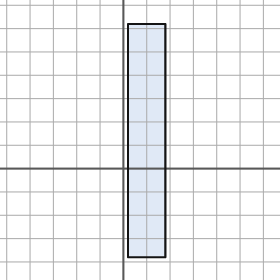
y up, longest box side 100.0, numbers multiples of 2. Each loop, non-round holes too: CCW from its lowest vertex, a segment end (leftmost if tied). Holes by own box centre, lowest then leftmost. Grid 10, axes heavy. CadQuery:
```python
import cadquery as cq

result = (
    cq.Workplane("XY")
    .moveTo(2.0, -38.0)
    .lineTo(18.0, -38.0)
    .lineTo(18.0, 62.0)
    .lineTo(2.0, 62.0)
    .close()
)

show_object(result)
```